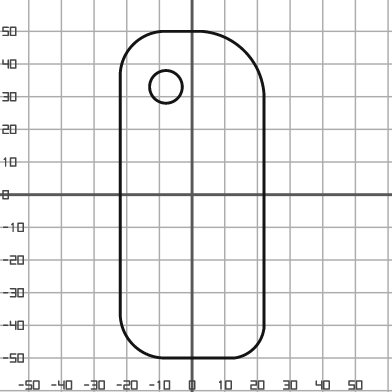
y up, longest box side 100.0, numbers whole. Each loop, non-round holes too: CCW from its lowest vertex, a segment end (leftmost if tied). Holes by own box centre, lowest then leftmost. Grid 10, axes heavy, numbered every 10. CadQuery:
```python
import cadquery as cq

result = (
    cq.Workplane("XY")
    .moveTo(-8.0, -50.0)
    .lineTo(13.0, -50.0)
    .threePointArc((19.0, -47.0), (22.0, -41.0))
    .lineTo(22.0, 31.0)
    .threePointArc((16.0, 44.0), (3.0, 50.0))
    .lineTo(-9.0, 50.0)
    .threePointArc((-18.0, 46.0), (-22.0, 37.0))
    .lineTo(-22.0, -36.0)
    .threePointArc((-18.0, -46.0), (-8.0, -50.0))
    .close()
    .moveTo(-8.0, 33.0)
    .circle(5.0)
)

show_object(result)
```